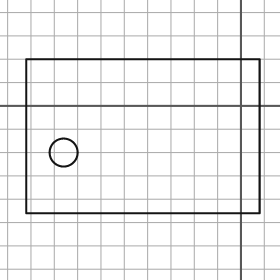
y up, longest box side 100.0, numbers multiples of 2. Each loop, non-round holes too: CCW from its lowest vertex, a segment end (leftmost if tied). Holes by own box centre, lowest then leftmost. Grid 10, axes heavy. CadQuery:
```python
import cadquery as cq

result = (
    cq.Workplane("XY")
    .moveTo(-92.0, -46.0)
    .lineTo(8.0, -46.0)
    .lineTo(8.0, 20.0)
    .lineTo(-92.0, 20.0)
    .close()
    .moveTo(-76.0, -20.0)
    .circle(6.0)
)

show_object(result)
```